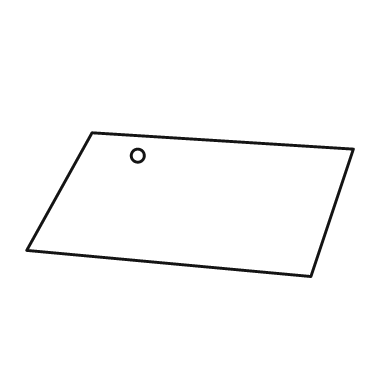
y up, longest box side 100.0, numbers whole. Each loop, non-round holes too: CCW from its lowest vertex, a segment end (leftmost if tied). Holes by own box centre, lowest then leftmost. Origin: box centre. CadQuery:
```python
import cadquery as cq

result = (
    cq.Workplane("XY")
    .moveTo(37.0, -22.0)
    .lineTo(50.0, 17.0)
    .lineTo(-30.0, 22.0)
    .lineTo(-50.0, -14.0)
    .close()
    .moveTo(-16.0, 15.0)
    .circle(2.0)
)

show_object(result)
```